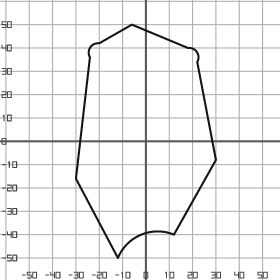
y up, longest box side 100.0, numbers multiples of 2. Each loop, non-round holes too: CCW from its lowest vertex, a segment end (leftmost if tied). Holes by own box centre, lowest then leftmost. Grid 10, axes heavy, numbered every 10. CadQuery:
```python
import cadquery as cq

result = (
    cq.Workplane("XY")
    .moveTo(-12.0, -50.0)
    .threePointArc((-2.0, -40.0), (12.0, -40.0))
    .lineTo(30.0, -8.0)
    .lineTo(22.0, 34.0)
    .threePointArc((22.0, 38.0), (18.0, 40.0))
    .lineTo(-6.0, 50.0)
    .lineTo(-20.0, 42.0)
    .threePointArc((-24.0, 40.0), (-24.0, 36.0))
    .lineTo(-30.0, -16.0)
    .close()
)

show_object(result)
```